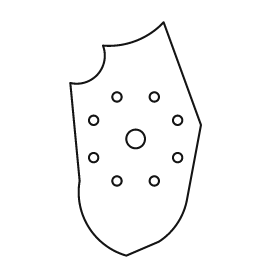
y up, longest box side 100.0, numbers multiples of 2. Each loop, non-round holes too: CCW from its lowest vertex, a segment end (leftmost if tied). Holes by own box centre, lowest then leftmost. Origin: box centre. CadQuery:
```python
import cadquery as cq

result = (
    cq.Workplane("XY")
    .moveTo(-4.0, -50.0)
    .lineTo(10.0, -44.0)
    .threePointArc((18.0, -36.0), (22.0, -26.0))
    .lineTo(28.0, 6.0)
    .lineTo(12.0, 50.0)
    .threePointArc((0.0, 42.0), (-14.0, 40.0))
    .threePointArc((-16.0, 28.0), (-28.0, 24.0))
    .lineTo(-24.0, -18.0)
    .threePointArc((-20.0, -38.0), (-4.0, -50.0))
    .close()
    .moveTo(-8.0, -18.0)
    .circle(2.0)
    .moveTo(8.0, -18.0)
    .circle(2.0)
    .moveTo(-18.0, -8.0)
    .circle(2.0)
    .moveTo(18.0, -8.0)
    .circle(2.0)
    .moveTo(0.0, 0.0)
    .circle(4.0)
    .moveTo(-18.0, 8.0)
    .circle(2.0)
    .moveTo(18.0, 8.0)
    .circle(2.0)
    .moveTo(-8.0, 18.0)
    .circle(2.0)
    .moveTo(8.0, 18.0)
    .circle(2.0)
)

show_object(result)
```